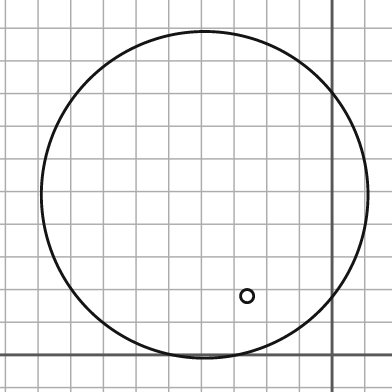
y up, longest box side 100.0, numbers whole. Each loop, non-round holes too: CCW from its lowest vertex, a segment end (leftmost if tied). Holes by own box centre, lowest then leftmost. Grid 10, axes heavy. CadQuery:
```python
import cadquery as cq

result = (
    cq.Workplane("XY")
    .moveTo(-39.0, 49.0)
    .circle(50.0)
    .moveTo(-26.0, 18.0)
    .circle(2.0)
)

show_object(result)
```